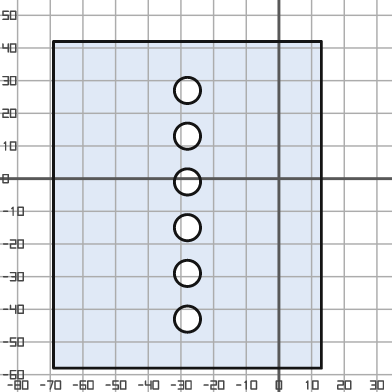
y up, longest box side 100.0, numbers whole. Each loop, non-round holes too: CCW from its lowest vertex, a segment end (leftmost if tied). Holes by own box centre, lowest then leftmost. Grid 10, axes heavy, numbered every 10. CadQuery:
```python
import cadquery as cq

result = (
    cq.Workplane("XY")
    .moveTo(-69.0, -58.0)
    .lineTo(13.0, -58.0)
    .lineTo(13.0, 42.0)
    .lineTo(-69.0, 42.0)
    .close()
    .moveTo(-28.0, -43.0)
    .circle(4.0)
    .moveTo(-28.0, -29.0)
    .circle(4.0)
    .moveTo(-28.0, -15.0)
    .circle(4.0)
    .moveTo(-28.0, -1.0)
    .circle(4.0)
    .moveTo(-28.0, 13.0)
    .circle(4.0)
    .moveTo(-28.0, 27.0)
    .circle(4.0)
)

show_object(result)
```